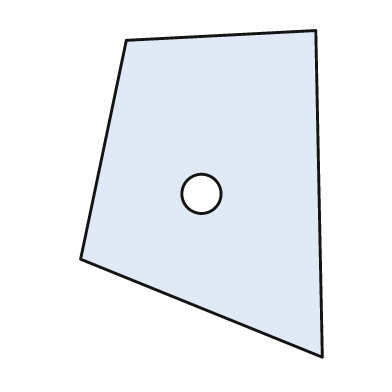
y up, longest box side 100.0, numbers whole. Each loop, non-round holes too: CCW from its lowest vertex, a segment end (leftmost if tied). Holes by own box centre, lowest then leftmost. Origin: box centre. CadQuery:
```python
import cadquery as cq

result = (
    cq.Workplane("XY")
    .moveTo(37.0, -50.0)
    .lineTo(35.0, 50.0)
    .lineTo(-23.0, 47.0)
    .lineTo(-37.0, -20.0)
    .close()
    .moveTo(0.0, 0.0)
    .circle(6.0)
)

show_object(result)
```